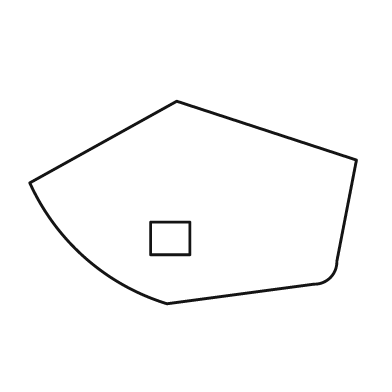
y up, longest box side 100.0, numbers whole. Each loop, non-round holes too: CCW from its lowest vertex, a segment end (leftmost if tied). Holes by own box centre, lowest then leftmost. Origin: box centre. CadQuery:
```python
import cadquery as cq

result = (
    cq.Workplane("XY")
    .moveTo(-8.0, -31.0)
    .lineTo(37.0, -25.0)
    .threePointArc((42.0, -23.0), (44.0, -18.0))
    .lineTo(50.0, 13.0)
    .lineTo(-5.0, 31.0)
    .lineTo(-50.0, 6.0)
    .threePointArc((-33.0, -17.0), (-8.0, -31.0))
    .close()
    .moveTo(-13.0, -16.0)
    .lineTo(-1.0, -16.0)
    .lineTo(-1.0, -6.0)
    .lineTo(-13.0, -6.0)
    .close()
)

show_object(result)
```